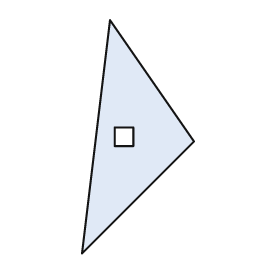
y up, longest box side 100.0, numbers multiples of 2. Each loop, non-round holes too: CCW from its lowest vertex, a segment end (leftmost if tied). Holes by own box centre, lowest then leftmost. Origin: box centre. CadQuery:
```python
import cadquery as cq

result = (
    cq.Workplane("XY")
    .moveTo(-24.0, -50.0)
    .lineTo(24.0, -2.0)
    .lineTo(-12.0, 50.0)
    .close()
    .moveTo(-10.0, -4.0)
    .lineTo(-2.0, -4.0)
    .lineTo(-2.0, 4.0)
    .lineTo(-10.0, 4.0)
    .close()
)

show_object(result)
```